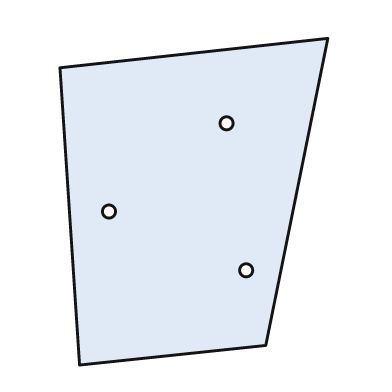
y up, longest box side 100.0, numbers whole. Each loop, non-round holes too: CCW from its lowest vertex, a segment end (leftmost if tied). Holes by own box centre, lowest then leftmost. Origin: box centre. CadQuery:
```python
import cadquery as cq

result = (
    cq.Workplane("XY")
    .moveTo(-35.0, -50.0)
    .lineTo(22.0, -44.0)
    .lineTo(41.0, 50.0)
    .lineTo(-41.0, 41.0)
    .close()
    .moveTo(16.0, -21.0)
    .circle(2.0)
    .moveTo(-26.0, -3.0)
    .circle(2.0)
    .moveTo(10.0, 24.0)
    .circle(2.0)
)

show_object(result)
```